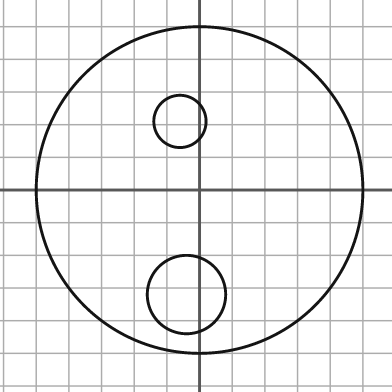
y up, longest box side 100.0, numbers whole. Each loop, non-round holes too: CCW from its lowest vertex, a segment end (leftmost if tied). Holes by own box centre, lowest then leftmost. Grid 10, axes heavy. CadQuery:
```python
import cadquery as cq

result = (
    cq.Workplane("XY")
    .moveTo(0.0, 0.0)
    .circle(50.0)
    .moveTo(-4.0, -32.0)
    .circle(12.0)
    .moveTo(-6.0, 21.0)
    .circle(8.0)
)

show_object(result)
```